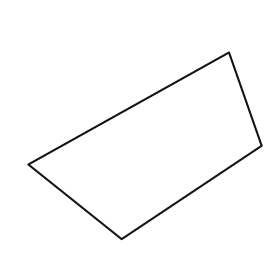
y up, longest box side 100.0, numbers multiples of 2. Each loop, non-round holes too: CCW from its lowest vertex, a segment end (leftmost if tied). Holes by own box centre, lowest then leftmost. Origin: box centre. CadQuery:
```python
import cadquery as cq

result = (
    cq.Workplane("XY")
    .moveTo(-10.0, -40.0)
    .lineTo(50.0, 0.0)
    .lineTo(36.0, 40.0)
    .lineTo(-50.0, -8.0)
    .close()
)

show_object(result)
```